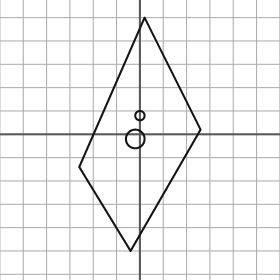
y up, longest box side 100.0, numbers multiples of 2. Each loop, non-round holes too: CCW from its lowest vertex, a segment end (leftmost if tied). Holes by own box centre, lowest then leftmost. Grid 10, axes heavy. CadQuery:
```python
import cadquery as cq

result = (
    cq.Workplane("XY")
    .moveTo(-4.0, -50.0)
    .lineTo(26.0, 2.0)
    .lineTo(2.0, 50.0)
    .lineTo(-26.0, -14.0)
    .close()
    .moveTo(-2.0, -2.0)
    .circle(4.0)
    .moveTo(0.0, 8.0)
    .circle(2.0)
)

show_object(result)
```